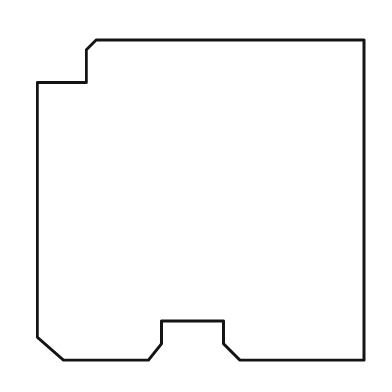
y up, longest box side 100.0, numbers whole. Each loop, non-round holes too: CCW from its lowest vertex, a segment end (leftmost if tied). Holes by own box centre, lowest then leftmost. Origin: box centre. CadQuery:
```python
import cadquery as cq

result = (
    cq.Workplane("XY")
    .moveTo(-42.0, -49.0)
    .lineTo(-16.0, -49.0)
    .lineTo(-12.0, -44.0)
    .lineTo(-12.0, -37.0)
    .lineTo(7.0, -37.0)
    .lineTo(7.0, -44.0)
    .lineTo(12.0, -49.0)
    .lineTo(50.0, -49.0)
    .lineTo(50.0, 49.0)
    .lineTo(-32.0, 49.0)
    .lineTo(-35.0, 46.0)
    .lineTo(-35.0, 36.0)
    .lineTo(-50.0, 36.0)
    .lineTo(-50.0, -42.0)
    .close()
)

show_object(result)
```